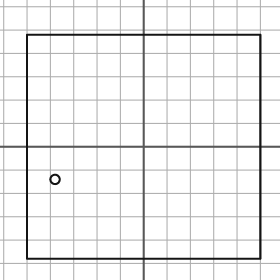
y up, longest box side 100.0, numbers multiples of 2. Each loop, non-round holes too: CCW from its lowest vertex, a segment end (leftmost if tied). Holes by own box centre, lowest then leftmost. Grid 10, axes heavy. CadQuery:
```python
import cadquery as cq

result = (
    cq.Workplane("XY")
    .moveTo(-50.0, -48.0)
    .lineTo(50.0, -48.0)
    .lineTo(50.0, 48.0)
    .lineTo(-50.0, 48.0)
    .close()
    .moveTo(-38.0, -14.0)
    .circle(2.0)
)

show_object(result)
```